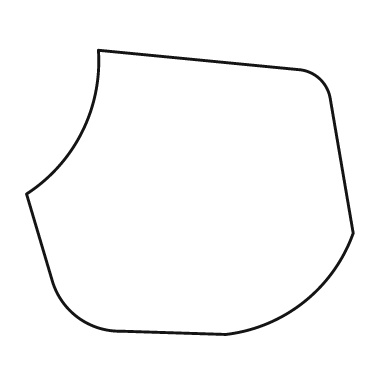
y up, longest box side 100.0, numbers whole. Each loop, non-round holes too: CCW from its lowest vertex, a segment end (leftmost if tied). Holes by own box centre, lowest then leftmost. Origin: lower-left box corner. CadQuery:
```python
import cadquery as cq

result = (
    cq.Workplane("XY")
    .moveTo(61.0, 0.0)
    .threePointArc((85.0, 10.0), (100.0, 31.0))
    .lineTo(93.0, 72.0)
    .threePointArc((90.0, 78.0), (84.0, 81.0))
    .lineTo(22.0, 87.0)
    .threePointArc((17.0, 62.0), (0.0, 43.0))
    .lineTo(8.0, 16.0)
    .threePointArc((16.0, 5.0), (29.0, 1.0))
    .close()
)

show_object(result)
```